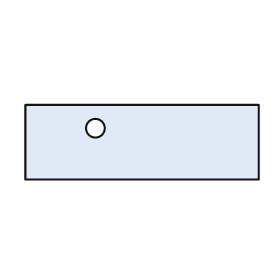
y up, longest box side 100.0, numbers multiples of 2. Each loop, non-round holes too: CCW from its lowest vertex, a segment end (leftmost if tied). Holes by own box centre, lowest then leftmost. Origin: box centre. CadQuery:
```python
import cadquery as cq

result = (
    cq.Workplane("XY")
    .moveTo(-50.0, -16.0)
    .lineTo(50.0, -16.0)
    .lineTo(50.0, 16.0)
    .lineTo(-50.0, 16.0)
    .close()
    .moveTo(-20.0, 6.0)
    .circle(4.0)
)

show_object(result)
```